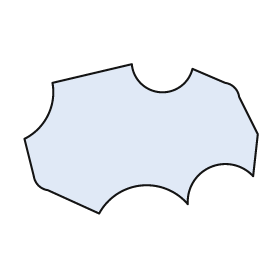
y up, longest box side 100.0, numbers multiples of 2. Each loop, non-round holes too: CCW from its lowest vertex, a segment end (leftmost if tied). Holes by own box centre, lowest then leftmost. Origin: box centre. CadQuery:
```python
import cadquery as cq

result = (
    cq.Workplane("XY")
    .moveTo(-18.0, -32.0)
    .threePointArc((0.0, -20.0), (20.0, -28.0))
    .threePointArc((30.0, -12.0), (48.0, -16.0))
    .lineTo(50.0, 2.0)
    .lineTo(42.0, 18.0)
    .threePointArc((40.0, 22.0), (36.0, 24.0))
    .lineTo(22.0, 30.0)
    .threePointArc((8.0, 20.0), (-4.0, 32.0))
    .lineTo(-38.0, 24.0)
    .threePointArc((-40.0, 10.0), (-50.0, 0.0))
    .lineTo(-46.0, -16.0)
    .threePointArc((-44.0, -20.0), (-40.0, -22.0))
    .close()
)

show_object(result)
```